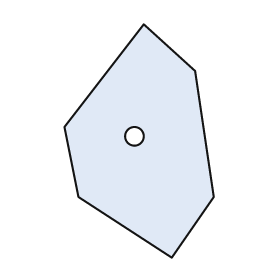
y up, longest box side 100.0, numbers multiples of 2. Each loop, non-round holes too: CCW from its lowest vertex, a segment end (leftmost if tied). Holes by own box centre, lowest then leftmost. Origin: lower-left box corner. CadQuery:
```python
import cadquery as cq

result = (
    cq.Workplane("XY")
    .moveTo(46.0, 0.0)
    .lineTo(64.0, 26.0)
    .lineTo(56.0, 80.0)
    .lineTo(34.0, 100.0)
    .lineTo(0.0, 56.0)
    .lineTo(6.0, 26.0)
    .close()
    .moveTo(30.0, 52.0)
    .circle(4.0)
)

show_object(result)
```